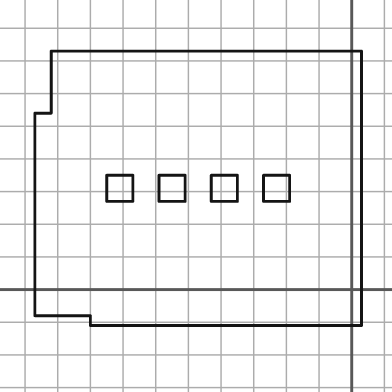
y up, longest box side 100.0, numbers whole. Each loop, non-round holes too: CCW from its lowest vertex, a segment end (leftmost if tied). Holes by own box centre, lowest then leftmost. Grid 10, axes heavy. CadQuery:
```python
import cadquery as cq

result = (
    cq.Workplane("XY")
    .moveTo(-80.0, -11.0)
    .lineTo(3.0, -11.0)
    .lineTo(3.0, 73.0)
    .lineTo(-92.0, 73.0)
    .lineTo(-92.0, 54.0)
    .lineTo(-97.0, 54.0)
    .lineTo(-97.0, -8.0)
    .lineTo(-80.0, -8.0)
    .close()
    .moveTo(-75.0, 27.0)
    .lineTo(-67.0, 27.0)
    .lineTo(-67.0, 35.0)
    .lineTo(-75.0, 35.0)
    .close()
    .moveTo(-59.0, 27.0)
    .lineTo(-51.0, 27.0)
    .lineTo(-51.0, 35.0)
    .lineTo(-59.0, 35.0)
    .close()
    .moveTo(-43.0, 27.0)
    .lineTo(-35.0, 27.0)
    .lineTo(-35.0, 35.0)
    .lineTo(-43.0, 35.0)
    .close()
    .moveTo(-27.0, 27.0)
    .lineTo(-19.0, 27.0)
    .lineTo(-19.0, 35.0)
    .lineTo(-27.0, 35.0)
    .close()
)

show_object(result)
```